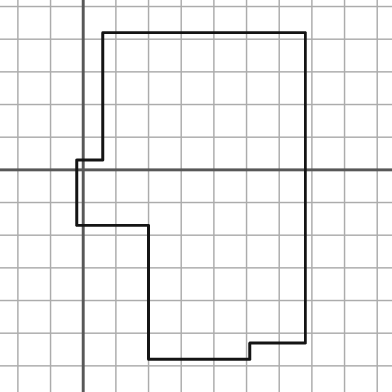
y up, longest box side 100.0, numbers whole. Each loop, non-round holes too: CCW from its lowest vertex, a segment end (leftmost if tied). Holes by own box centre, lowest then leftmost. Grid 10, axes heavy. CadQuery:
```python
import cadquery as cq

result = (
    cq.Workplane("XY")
    .moveTo(20.0, -58.0)
    .lineTo(51.0, -58.0)
    .lineTo(51.0, -53.0)
    .lineTo(68.0, -53.0)
    .lineTo(68.0, 42.0)
    .lineTo(6.0, 42.0)
    .lineTo(6.0, 3.0)
    .lineTo(-2.0, 3.0)
    .lineTo(-2.0, -17.0)
    .lineTo(20.0, -17.0)
    .close()
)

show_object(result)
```